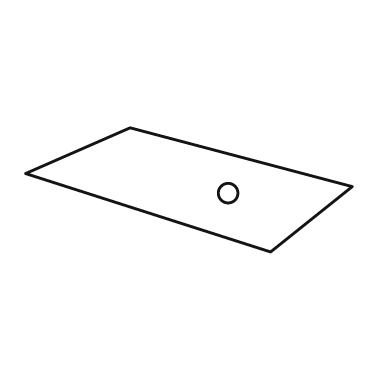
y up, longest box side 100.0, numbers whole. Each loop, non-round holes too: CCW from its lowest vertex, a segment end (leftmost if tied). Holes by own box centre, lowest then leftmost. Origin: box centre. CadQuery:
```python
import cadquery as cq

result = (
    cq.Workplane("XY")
    .moveTo(25.0, -19.0)
    .lineTo(50.0, 1.0)
    .lineTo(-18.0, 19.0)
    .lineTo(-50.0, 5.0)
    .close()
    .moveTo(12.0, -1.0)
    .circle(3.0)
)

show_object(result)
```